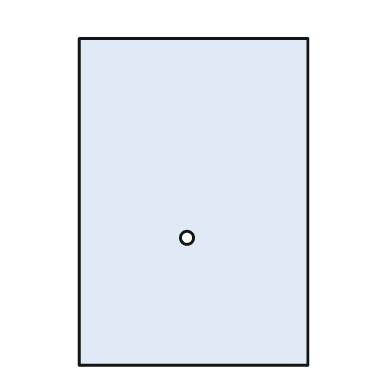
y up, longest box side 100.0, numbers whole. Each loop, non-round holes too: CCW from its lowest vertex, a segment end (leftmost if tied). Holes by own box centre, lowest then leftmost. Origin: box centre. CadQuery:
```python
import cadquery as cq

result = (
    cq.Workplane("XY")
    .moveTo(-35.0, -50.0)
    .lineTo(35.0, -50.0)
    .lineTo(35.0, 50.0)
    .lineTo(-35.0, 50.0)
    .close()
    .moveTo(-2.0, -11.0)
    .circle(2.0)
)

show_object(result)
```